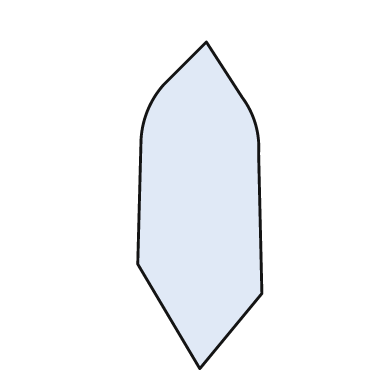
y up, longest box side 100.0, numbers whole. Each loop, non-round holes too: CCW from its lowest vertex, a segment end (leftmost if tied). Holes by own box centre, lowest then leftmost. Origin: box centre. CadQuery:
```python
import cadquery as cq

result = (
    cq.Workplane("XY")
    .moveTo(0.0, -50.0)
    .lineTo(19.0, -27.0)
    .lineTo(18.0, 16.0)
    .threePointArc((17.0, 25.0), (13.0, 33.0))
    .lineTo(2.0, 50.0)
    .lineTo(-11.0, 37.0)
    .threePointArc((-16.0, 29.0), (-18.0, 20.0))
    .lineTo(-19.0, -18.0)
    .close()
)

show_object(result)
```